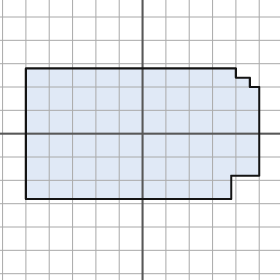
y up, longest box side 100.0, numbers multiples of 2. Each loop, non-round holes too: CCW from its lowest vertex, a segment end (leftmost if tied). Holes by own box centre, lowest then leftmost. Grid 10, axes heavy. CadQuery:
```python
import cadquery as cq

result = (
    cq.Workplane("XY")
    .moveTo(-50.0, -28.0)
    .lineTo(38.0, -28.0)
    .lineTo(38.0, -18.0)
    .lineTo(50.0, -18.0)
    .lineTo(50.0, 20.0)
    .lineTo(46.0, 20.0)
    .lineTo(46.0, 24.0)
    .lineTo(40.0, 24.0)
    .lineTo(40.0, 28.0)
    .lineTo(-50.0, 28.0)
    .close()
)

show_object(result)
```